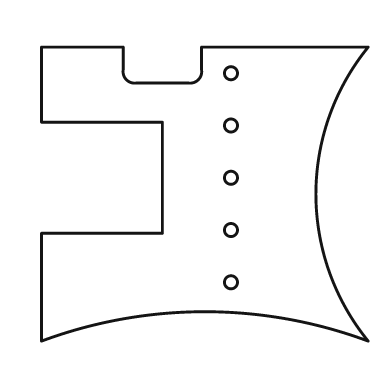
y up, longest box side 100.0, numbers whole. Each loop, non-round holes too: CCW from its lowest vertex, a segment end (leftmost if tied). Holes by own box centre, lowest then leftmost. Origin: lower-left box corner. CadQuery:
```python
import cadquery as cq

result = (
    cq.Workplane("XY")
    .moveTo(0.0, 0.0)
    .threePointArc((50.0, 9.0), (100.0, 0.0))
    .threePointArc((84.0, 45.0), (100.0, 90.0))
    .lineTo(49.0, 90.0)
    .lineTo(49.0, 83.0)
    .threePointArc((48.0, 80.0), (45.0, 79.0))
    .lineTo(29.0, 79.0)
    .threePointArc((26.0, 80.0), (25.0, 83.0))
    .lineTo(25.0, 90.0)
    .lineTo(0.0, 90.0)
    .lineTo(0.0, 67.0)
    .lineTo(37.0, 67.0)
    .lineTo(37.0, 33.0)
    .lineTo(0.0, 33.0)
    .close()
    .moveTo(58.0, 18.0)
    .circle(2.0)
    .moveTo(58.0, 34.0)
    .circle(2.0)
    .moveTo(58.0, 50.0)
    .circle(2.0)
    .moveTo(58.0, 66.0)
    .circle(2.0)
    .moveTo(58.0, 82.0)
    .circle(2.0)
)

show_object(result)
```